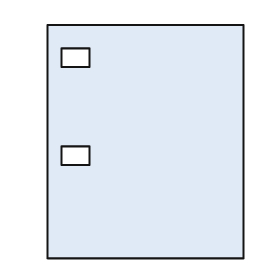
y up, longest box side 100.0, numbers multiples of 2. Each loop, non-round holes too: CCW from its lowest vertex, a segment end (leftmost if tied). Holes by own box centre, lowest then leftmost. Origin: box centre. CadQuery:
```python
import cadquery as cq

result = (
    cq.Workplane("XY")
    .moveTo(-42.0, -50.0)
    .lineTo(42.0, -50.0)
    .lineTo(42.0, 50.0)
    .lineTo(-42.0, 50.0)
    .close()
    .moveTo(-36.0, -10.0)
    .lineTo(-24.0, -10.0)
    .lineTo(-24.0, -2.0)
    .lineTo(-36.0, -2.0)
    .close()
    .moveTo(-36.0, 32.0)
    .lineTo(-24.0, 32.0)
    .lineTo(-24.0, 40.0)
    .lineTo(-36.0, 40.0)
    .close()
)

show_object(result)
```